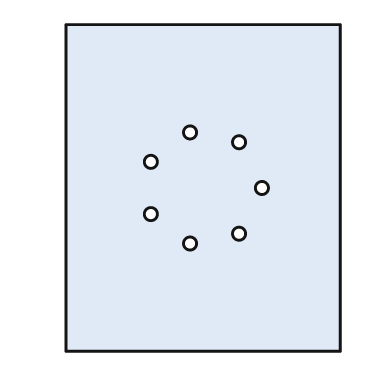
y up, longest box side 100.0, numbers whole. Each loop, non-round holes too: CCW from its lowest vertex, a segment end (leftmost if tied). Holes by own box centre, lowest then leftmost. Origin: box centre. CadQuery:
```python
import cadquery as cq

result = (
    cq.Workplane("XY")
    .moveTo(-42.0, -50.0)
    .lineTo(42.0, -50.0)
    .lineTo(42.0, 50.0)
    .lineTo(-42.0, 50.0)
    .close()
    .moveTo(-4.0, -17.0)
    .circle(2.0)
    .moveTo(11.0, -14.0)
    .circle(2.0)
    .moveTo(-16.0, -8.0)
    .circle(2.0)
    .moveTo(18.0, 0.0)
    .circle(2.0)
    .moveTo(-16.0, 8.0)
    .circle(2.0)
    .moveTo(11.0, 14.0)
    .circle(2.0)
    .moveTo(-4.0, 17.0)
    .circle(2.0)
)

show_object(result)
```